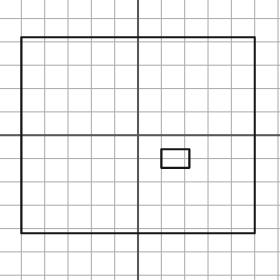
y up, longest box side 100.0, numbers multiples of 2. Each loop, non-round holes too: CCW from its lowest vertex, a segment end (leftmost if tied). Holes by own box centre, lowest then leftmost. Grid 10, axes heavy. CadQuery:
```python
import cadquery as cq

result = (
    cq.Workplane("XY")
    .moveTo(-50.0, -42.0)
    .lineTo(50.0, -42.0)
    .lineTo(50.0, 42.0)
    .lineTo(-50.0, 42.0)
    .close()
    .moveTo(10.0, -14.0)
    .lineTo(22.0, -14.0)
    .lineTo(22.0, -6.0)
    .lineTo(10.0, -6.0)
    .close()
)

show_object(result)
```